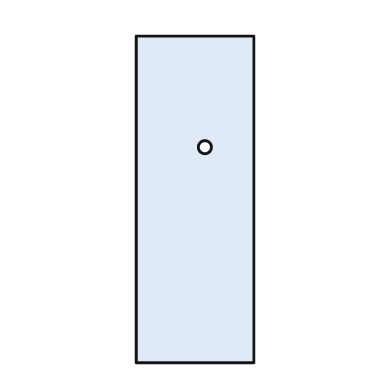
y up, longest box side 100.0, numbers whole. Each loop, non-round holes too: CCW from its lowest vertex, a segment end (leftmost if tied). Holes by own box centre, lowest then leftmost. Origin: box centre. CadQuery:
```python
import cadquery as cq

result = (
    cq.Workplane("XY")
    .moveTo(-18.0, -50.0)
    .lineTo(18.0, -50.0)
    .lineTo(18.0, 50.0)
    .lineTo(-18.0, 50.0)
    .close()
    .moveTo(3.0, 16.0)
    .circle(2.0)
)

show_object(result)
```